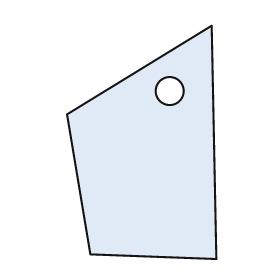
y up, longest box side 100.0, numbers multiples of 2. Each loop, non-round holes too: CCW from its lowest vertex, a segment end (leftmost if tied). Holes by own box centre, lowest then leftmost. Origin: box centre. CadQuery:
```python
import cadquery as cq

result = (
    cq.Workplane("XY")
    .moveTo(32.0, -50.0)
    .lineTo(30.0, 50.0)
    .lineTo(-32.0, 12.0)
    .lineTo(-22.0, -48.0)
    .close()
    .moveTo(12.0, 22.0)
    .circle(6.0)
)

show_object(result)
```